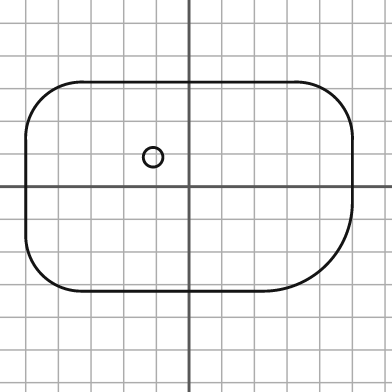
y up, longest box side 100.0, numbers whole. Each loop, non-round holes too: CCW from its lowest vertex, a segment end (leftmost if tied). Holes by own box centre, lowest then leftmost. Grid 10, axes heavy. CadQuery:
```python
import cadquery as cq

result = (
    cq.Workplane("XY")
    .moveTo(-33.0, -32.0)
    .lineTo(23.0, -32.0)
    .threePointArc((42.0, -24.0), (50.0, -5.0))
    .lineTo(50.0, 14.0)
    .threePointArc((45.0, 27.0), (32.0, 32.0))
    .lineTo(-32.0, 32.0)
    .threePointArc((-45.0, 27.0), (-50.0, 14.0))
    .lineTo(-50.0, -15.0)
    .threePointArc((-45.0, -27.0), (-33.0, -32.0))
    .close()
    .moveTo(-11.0, 9.0)
    .circle(3.0)
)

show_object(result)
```